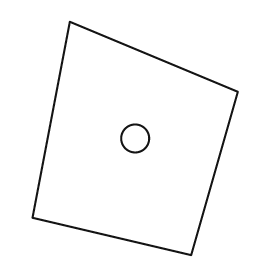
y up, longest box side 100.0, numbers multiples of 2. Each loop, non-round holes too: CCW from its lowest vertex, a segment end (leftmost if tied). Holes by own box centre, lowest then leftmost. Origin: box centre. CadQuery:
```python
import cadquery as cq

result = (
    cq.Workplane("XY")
    .moveTo(24.0, -50.0)
    .lineTo(44.0, 20.0)
    .lineTo(-28.0, 50.0)
    .lineTo(-44.0, -34.0)
    .close()
    .moveTo(0.0, 0.0)
    .circle(6.0)
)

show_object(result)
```